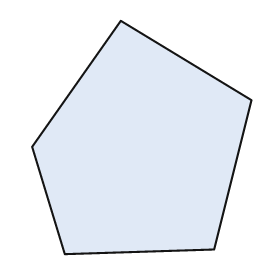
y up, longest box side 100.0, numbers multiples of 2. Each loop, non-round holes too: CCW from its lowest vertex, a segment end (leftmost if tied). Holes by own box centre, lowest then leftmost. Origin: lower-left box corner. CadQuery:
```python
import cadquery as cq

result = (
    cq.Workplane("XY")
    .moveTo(14.0, 0.0)
    .lineTo(78.0, 2.0)
    .lineTo(94.0, 66.0)
    .lineTo(38.0, 100.0)
    .lineTo(0.0, 46.0)
    .close()
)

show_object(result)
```